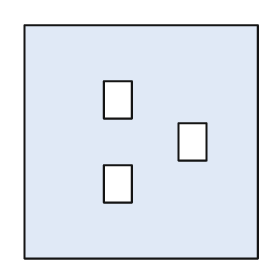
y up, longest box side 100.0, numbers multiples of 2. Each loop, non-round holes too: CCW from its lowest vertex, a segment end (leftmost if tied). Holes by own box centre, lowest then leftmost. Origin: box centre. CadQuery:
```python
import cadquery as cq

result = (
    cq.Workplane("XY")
    .moveTo(-50.0, -50.0)
    .lineTo(50.0, -50.0)
    .lineTo(50.0, 50.0)
    .lineTo(-50.0, 50.0)
    .close()
    .moveTo(-16.0, -26.0)
    .lineTo(-4.0, -26.0)
    .lineTo(-4.0, -10.0)
    .lineTo(-16.0, -10.0)
    .close()
    .moveTo(16.0, -8.0)
    .lineTo(28.0, -8.0)
    .lineTo(28.0, 8.0)
    .lineTo(16.0, 8.0)
    .close()
    .moveTo(-16.0, 10.0)
    .lineTo(-4.0, 10.0)
    .lineTo(-4.0, 26.0)
    .lineTo(-16.0, 26.0)
    .close()
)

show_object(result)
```